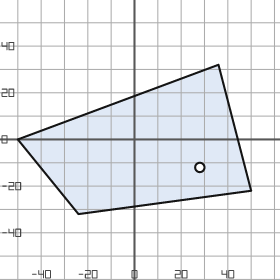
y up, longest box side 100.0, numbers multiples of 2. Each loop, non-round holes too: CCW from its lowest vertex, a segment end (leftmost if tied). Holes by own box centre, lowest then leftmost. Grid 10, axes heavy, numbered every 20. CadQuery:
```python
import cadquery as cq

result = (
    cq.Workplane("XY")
    .moveTo(-24.0, -32.0)
    .lineTo(50.0, -22.0)
    .lineTo(36.0, 32.0)
    .lineTo(-50.0, 0.0)
    .close()
    .moveTo(28.0, -12.0)
    .circle(2.0)
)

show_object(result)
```